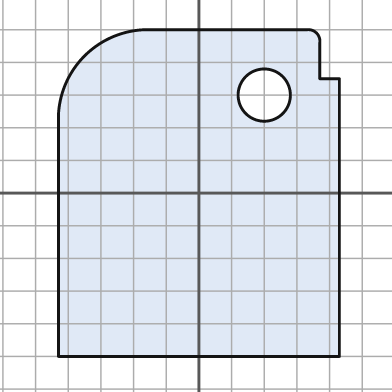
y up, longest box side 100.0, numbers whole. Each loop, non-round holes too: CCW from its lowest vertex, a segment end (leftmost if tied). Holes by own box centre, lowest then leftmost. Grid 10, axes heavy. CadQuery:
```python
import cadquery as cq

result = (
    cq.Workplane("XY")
    .moveTo(-43.0, -50.0)
    .lineTo(43.0, -50.0)
    .lineTo(43.0, 35.0)
    .lineTo(37.0, 35.0)
    .lineTo(37.0, 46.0)
    .threePointArc((36.0, 49.0), (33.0, 50.0))
    .lineTo(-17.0, 50.0)
    .threePointArc((-35.0, 42.0), (-43.0, 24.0))
    .close()
    .moveTo(20.0, 30.0)
    .circle(8.0)
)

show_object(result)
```